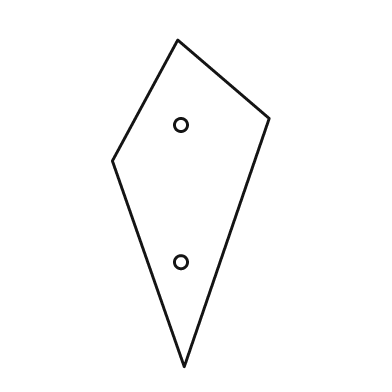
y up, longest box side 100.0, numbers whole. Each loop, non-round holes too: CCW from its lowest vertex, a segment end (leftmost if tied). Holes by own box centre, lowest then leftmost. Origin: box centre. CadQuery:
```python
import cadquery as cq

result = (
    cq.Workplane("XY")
    .moveTo(-2.0, -50.0)
    .lineTo(24.0, 26.0)
    .lineTo(-4.0, 50.0)
    .lineTo(-24.0, 13.0)
    .close()
    .moveTo(-3.0, -18.0)
    .circle(2.0)
    .moveTo(-3.0, 24.0)
    .circle(2.0)
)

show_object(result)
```